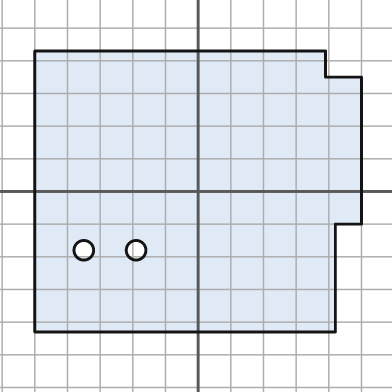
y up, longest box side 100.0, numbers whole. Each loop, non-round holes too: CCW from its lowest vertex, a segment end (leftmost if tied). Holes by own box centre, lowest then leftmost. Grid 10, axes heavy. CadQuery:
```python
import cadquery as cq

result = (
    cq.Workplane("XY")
    .moveTo(-50.0, -43.0)
    .lineTo(42.0, -43.0)
    .lineTo(42.0, -10.0)
    .lineTo(50.0, -10.0)
    .lineTo(50.0, 35.0)
    .lineTo(39.0, 35.0)
    .lineTo(39.0, 43.0)
    .lineTo(-50.0, 43.0)
    .close()
    .moveTo(-35.0, -18.0)
    .circle(3.0)
    .moveTo(-19.0, -18.0)
    .circle(3.0)
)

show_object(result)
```